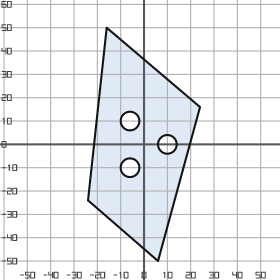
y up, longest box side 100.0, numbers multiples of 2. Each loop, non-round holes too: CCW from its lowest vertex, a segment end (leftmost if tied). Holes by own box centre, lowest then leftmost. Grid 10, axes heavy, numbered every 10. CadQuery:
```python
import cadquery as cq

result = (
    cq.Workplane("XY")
    .moveTo(6.0, -50.0)
    .lineTo(24.0, 16.0)
    .lineTo(-16.0, 50.0)
    .lineTo(-24.0, -24.0)
    .close()
    .moveTo(-6.0, -10.0)
    .circle(4.0)
    .moveTo(10.0, 0.0)
    .circle(4.0)
    .moveTo(-6.0, 10.0)
    .circle(4.0)
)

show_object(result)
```